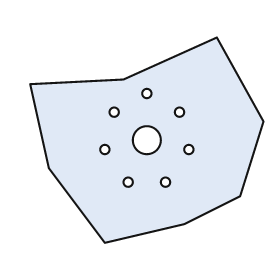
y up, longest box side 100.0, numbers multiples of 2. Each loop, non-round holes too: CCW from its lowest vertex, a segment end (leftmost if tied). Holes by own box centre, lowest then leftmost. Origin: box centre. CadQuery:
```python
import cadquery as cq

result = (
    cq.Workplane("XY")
    .moveTo(-18.0, -44.0)
    .lineTo(16.0, -36.0)
    .lineTo(40.0, -24.0)
    .lineTo(50.0, 8.0)
    .lineTo(30.0, 44.0)
    .lineTo(-10.0, 26.0)
    .lineTo(-50.0, 24.0)
    .lineTo(-42.0, -12.0)
    .close()
    .moveTo(-8.0, -18.0)
    .circle(2.0)
    .moveTo(8.0, -18.0)
    .circle(2.0)
    .moveTo(-18.0, -4.0)
    .circle(2.0)
    .moveTo(18.0, -4.0)
    .circle(2.0)
    .moveTo(0.0, 0.0)
    .circle(6.0)
    .moveTo(-14.0, 12.0)
    .circle(2.0)
    .moveTo(14.0, 12.0)
    .circle(2.0)
    .moveTo(0.0, 20.0)
    .circle(2.0)
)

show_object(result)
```